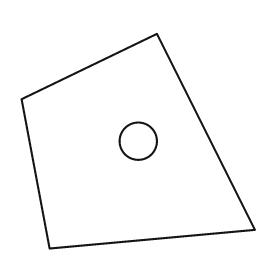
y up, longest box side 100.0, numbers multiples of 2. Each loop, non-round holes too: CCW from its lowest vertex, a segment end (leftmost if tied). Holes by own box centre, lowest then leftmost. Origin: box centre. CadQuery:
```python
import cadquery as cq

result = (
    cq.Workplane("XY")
    .moveTo(-38.0, -46.0)
    .lineTo(50.0, -38.0)
    .lineTo(8.0, 46.0)
    .lineTo(-50.0, 18.0)
    .close()
    .moveTo(0.0, 0.0)
    .circle(8.0)
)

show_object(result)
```